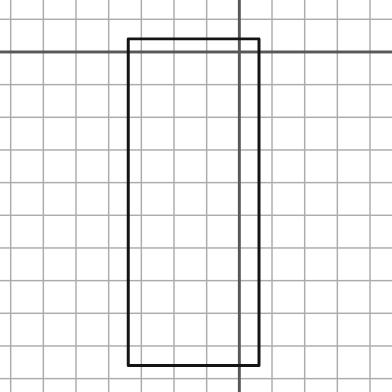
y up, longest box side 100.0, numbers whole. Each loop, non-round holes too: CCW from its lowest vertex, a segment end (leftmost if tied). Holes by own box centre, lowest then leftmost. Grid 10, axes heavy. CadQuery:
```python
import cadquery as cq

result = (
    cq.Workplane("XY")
    .moveTo(-34.0, -96.0)
    .lineTo(6.0, -96.0)
    .lineTo(6.0, 4.0)
    .lineTo(-34.0, 4.0)
    .close()
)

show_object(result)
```